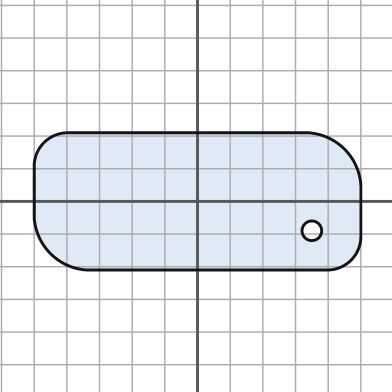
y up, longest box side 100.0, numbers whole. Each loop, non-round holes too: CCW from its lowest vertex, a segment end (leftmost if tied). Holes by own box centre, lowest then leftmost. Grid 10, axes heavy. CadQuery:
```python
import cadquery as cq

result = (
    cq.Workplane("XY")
    .moveTo(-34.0, -21.0)
    .lineTo(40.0, -21.0)
    .threePointArc((47.0, -18.0), (50.0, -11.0))
    .lineTo(50.0, 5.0)
    .threePointArc((45.0, 16.0), (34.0, 21.0))
    .lineTo(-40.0, 21.0)
    .threePointArc((-47.0, 18.0), (-50.0, 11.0))
    .lineTo(-50.0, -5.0)
    .threePointArc((-45.0, -16.0), (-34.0, -21.0))
    .close()
    .moveTo(35.0, -9.0)
    .circle(3.0)
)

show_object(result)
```